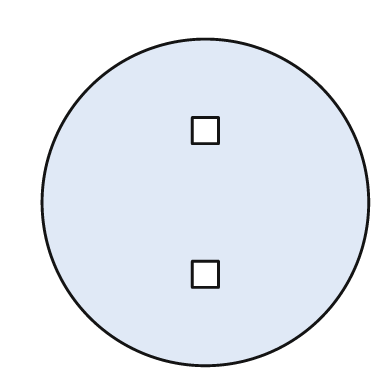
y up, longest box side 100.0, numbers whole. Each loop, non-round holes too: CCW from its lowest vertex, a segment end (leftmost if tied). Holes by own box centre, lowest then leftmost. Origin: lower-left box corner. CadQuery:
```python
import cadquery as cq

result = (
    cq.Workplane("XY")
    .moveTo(50.0, 50.0)
    .circle(50.0)
    .moveTo(46.0, 24.0)
    .lineTo(54.0, 24.0)
    .lineTo(54.0, 32.0)
    .lineTo(46.0, 32.0)
    .close()
    .moveTo(46.0, 68.0)
    .lineTo(54.0, 68.0)
    .lineTo(54.0, 76.0)
    .lineTo(46.0, 76.0)
    .close()
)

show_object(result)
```